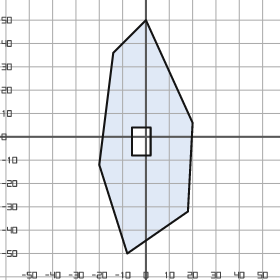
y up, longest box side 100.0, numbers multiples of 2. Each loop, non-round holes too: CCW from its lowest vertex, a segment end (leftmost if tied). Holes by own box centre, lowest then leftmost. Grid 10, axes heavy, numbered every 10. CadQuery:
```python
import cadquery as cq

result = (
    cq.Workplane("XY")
    .moveTo(-8.0, -50.0)
    .lineTo(18.0, -32.0)
    .lineTo(20.0, 6.0)
    .lineTo(0.0, 50.0)
    .lineTo(-14.0, 36.0)
    .lineTo(-20.0, -12.0)
    .close()
    .moveTo(-6.0, -8.0)
    .lineTo(2.0, -8.0)
    .lineTo(2.0, 4.0)
    .lineTo(-6.0, 4.0)
    .close()
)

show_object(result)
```